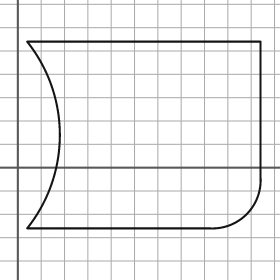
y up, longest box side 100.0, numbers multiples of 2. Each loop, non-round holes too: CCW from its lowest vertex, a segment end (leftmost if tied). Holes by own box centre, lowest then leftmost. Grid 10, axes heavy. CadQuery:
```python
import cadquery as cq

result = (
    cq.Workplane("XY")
    .moveTo(4.0, -26.0)
    .lineTo(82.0, -26.0)
    .threePointArc((98.0, -20.0), (104.0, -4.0))
    .lineTo(104.0, 54.0)
    .lineTo(4.0, 54.0)
    .threePointArc((18.0, 14.0), (4.0, -26.0))
    .close()
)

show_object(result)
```